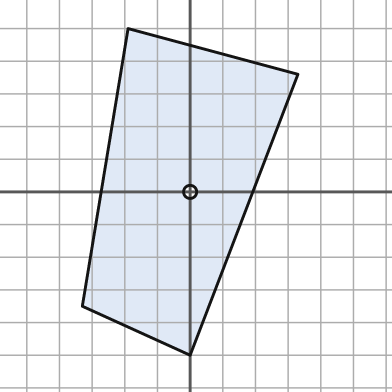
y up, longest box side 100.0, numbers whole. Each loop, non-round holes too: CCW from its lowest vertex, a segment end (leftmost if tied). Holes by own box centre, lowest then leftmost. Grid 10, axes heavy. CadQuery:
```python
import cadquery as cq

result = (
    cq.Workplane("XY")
    .moveTo(0.0, -50.0)
    .lineTo(33.0, 36.0)
    .lineTo(-19.0, 50.0)
    .lineTo(-33.0, -35.0)
    .close()
    .moveTo(0.0, 0.0)
    .circle(2.0)
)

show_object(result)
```